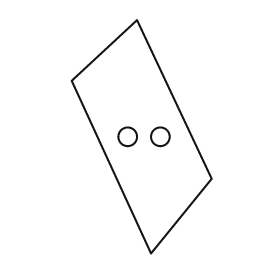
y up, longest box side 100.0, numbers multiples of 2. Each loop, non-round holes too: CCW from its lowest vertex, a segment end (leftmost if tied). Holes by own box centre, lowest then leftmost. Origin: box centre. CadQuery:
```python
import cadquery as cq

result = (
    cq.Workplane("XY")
    .moveTo(4.0, -50.0)
    .lineTo(30.0, -18.0)
    .lineTo(-2.0, 50.0)
    .lineTo(-30.0, 24.0)
    .close()
    .moveTo(-6.0, 0.0)
    .circle(4.0)
    .moveTo(8.0, 0.0)
    .circle(4.0)
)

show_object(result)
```